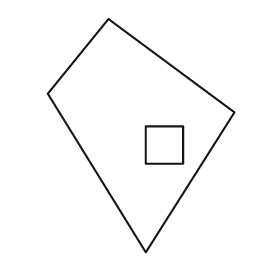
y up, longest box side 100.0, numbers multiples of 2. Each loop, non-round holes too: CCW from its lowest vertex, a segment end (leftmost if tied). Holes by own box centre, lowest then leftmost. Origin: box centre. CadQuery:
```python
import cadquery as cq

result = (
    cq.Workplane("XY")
    .moveTo(2.0, -50.0)
    .lineTo(40.0, 10.0)
    .lineTo(-14.0, 50.0)
    .lineTo(-40.0, 18.0)
    .close()
    .moveTo(2.0, -12.0)
    .lineTo(18.0, -12.0)
    .lineTo(18.0, 4.0)
    .lineTo(2.0, 4.0)
    .close()
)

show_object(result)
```